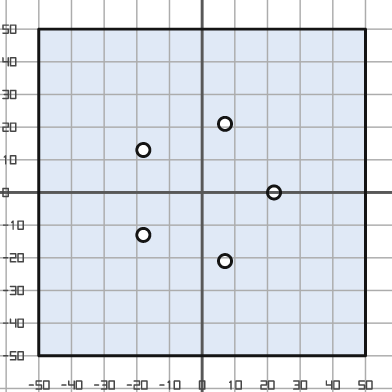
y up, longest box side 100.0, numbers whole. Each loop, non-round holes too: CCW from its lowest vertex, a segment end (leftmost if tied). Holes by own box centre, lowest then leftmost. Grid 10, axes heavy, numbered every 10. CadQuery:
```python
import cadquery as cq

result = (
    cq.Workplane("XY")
    .moveTo(-50.0, -50.0)
    .lineTo(50.0, -50.0)
    .lineTo(50.0, 50.0)
    .lineTo(-50.0, 50.0)
    .close()
    .moveTo(7.0, -21.0)
    .circle(2.0)
    .moveTo(-18.0, -13.0)
    .circle(2.0)
    .moveTo(22.0, 0.0)
    .circle(2.0)
    .moveTo(-18.0, 13.0)
    .circle(2.0)
    .moveTo(7.0, 21.0)
    .circle(2.0)
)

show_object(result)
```